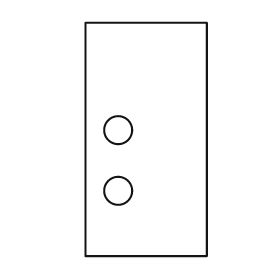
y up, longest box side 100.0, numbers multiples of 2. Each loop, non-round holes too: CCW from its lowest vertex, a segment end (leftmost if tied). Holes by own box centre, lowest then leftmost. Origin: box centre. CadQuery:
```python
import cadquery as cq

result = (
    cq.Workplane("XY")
    .moveTo(-26.0, -50.0)
    .lineTo(26.0, -50.0)
    .lineTo(26.0, 50.0)
    .lineTo(-26.0, 50.0)
    .close()
    .moveTo(-12.0, -22.0)
    .circle(6.0)
    .moveTo(-12.0, 4.0)
    .circle(6.0)
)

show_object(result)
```